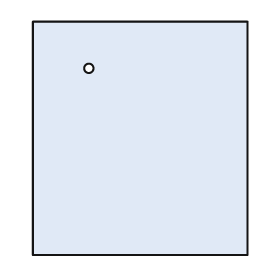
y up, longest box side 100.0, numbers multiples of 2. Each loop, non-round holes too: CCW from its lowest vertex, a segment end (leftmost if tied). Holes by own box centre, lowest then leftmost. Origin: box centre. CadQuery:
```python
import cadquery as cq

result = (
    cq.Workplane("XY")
    .moveTo(-46.0, -50.0)
    .lineTo(46.0, -50.0)
    .lineTo(46.0, 50.0)
    .lineTo(-46.0, 50.0)
    .close()
    .moveTo(-22.0, 30.0)
    .circle(2.0)
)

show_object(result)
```